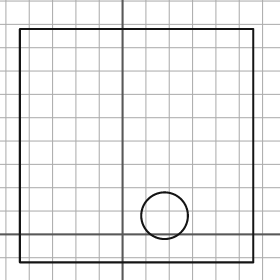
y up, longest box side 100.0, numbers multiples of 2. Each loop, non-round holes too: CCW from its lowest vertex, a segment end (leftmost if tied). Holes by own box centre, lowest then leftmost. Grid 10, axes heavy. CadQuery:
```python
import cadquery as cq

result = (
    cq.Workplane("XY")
    .moveTo(-44.0, -12.0)
    .lineTo(56.0, -12.0)
    .lineTo(56.0, 88.0)
    .lineTo(-44.0, 88.0)
    .close()
    .moveTo(18.0, 8.0)
    .circle(10.0)
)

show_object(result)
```